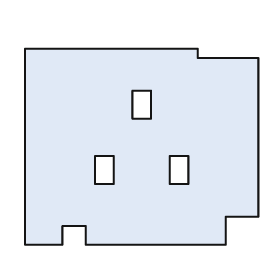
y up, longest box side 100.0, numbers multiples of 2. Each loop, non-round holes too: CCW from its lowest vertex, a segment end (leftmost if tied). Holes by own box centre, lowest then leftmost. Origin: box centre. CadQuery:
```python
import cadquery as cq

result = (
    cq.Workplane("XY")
    .moveTo(-50.0, -42.0)
    .lineTo(-34.0, -42.0)
    .lineTo(-34.0, -34.0)
    .lineTo(-24.0, -34.0)
    .lineTo(-24.0, -42.0)
    .lineTo(36.0, -42.0)
    .lineTo(36.0, -30.0)
    .lineTo(50.0, -30.0)
    .lineTo(50.0, 38.0)
    .lineTo(24.0, 38.0)
    .lineTo(24.0, 42.0)
    .lineTo(-50.0, 42.0)
    .close()
    .moveTo(-20.0, -16.0)
    .lineTo(-12.0, -16.0)
    .lineTo(-12.0, -4.0)
    .lineTo(-20.0, -4.0)
    .close()
    .moveTo(12.0, -16.0)
    .lineTo(20.0, -16.0)
    .lineTo(20.0, -4.0)
    .lineTo(12.0, -4.0)
    .close()
    .moveTo(-4.0, 12.0)
    .lineTo(4.0, 12.0)
    .lineTo(4.0, 24.0)
    .lineTo(-4.0, 24.0)
    .close()
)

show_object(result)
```